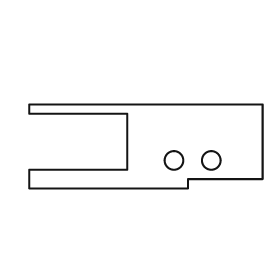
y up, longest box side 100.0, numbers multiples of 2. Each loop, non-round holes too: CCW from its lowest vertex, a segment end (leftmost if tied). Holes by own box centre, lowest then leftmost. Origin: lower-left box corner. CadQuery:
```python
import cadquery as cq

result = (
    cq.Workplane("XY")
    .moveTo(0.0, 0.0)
    .lineTo(68.0, 0.0)
    .lineTo(68.0, 4.0)
    .lineTo(100.0, 4.0)
    .lineTo(100.0, 36.0)
    .lineTo(0.0, 36.0)
    .lineTo(0.0, 32.0)
    .lineTo(42.0, 32.0)
    .lineTo(42.0, 8.0)
    .lineTo(0.0, 8.0)
    .close()
    .moveTo(62.0, 12.0)
    .circle(4.0)
    .moveTo(78.0, 12.0)
    .circle(4.0)
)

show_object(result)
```